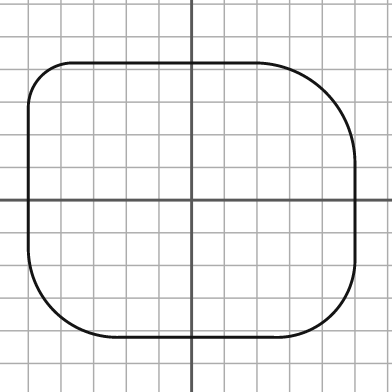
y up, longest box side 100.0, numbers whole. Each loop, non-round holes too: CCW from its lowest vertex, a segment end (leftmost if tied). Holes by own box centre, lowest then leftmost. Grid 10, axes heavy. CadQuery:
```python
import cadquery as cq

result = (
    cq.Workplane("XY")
    .moveTo(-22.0, -42.0)
    .lineTo(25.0, -42.0)
    .threePointArc((43.0, -35.0), (50.0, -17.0))
    .lineTo(50.0, 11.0)
    .threePointArc((41.0, 33.0), (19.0, 42.0))
    .lineTo(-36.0, 42.0)
    .threePointArc((-46.0, 38.0), (-50.0, 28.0))
    .lineTo(-50.0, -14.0)
    .threePointArc((-42.0, -34.0), (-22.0, -42.0))
    .close()
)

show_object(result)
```